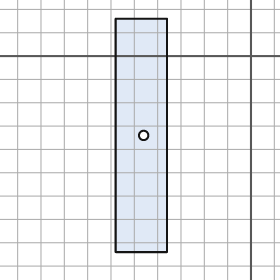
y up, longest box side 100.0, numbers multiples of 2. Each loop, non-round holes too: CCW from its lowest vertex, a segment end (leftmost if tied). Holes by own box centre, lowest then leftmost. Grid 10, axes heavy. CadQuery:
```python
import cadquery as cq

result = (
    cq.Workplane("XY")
    .moveTo(-58.0, -84.0)
    .lineTo(-36.0, -84.0)
    .lineTo(-36.0, 16.0)
    .lineTo(-58.0, 16.0)
    .close()
    .moveTo(-46.0, -34.0)
    .circle(2.0)
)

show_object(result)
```